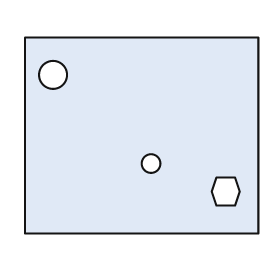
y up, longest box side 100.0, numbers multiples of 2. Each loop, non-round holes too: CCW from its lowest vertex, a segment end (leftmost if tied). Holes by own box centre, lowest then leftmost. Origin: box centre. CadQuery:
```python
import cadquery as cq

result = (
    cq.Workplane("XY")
    .moveTo(-50.0, -42.0)
    .lineTo(50.0, -42.0)
    .lineTo(50.0, 42.0)
    .lineTo(-50.0, 42.0)
    .close()
    .moveTo(32.0, -30.0)
    .lineTo(40.0, -30.0)
    .lineTo(42.0, -24.0)
    .lineTo(40.0, -18.0)
    .lineTo(32.0, -18.0)
    .lineTo(30.0, -24.0)
    .close()
    .moveTo(4.0, -12.0)
    .circle(4.0)
    .moveTo(-38.0, 26.0)
    .circle(6.0)
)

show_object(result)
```